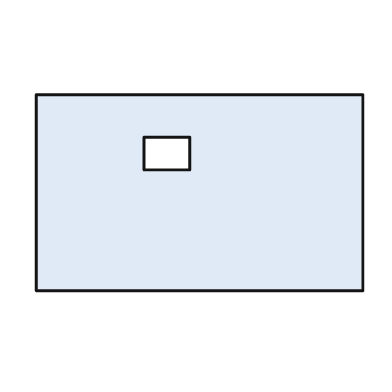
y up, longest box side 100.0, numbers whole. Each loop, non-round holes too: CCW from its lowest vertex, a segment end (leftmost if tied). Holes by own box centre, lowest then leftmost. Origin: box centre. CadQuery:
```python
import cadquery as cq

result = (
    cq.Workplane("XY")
    .moveTo(-50.0, -30.0)
    .lineTo(50.0, -30.0)
    .lineTo(50.0, 30.0)
    .lineTo(-50.0, 30.0)
    .close()
    .moveTo(-17.0, 7.0)
    .lineTo(-3.0, 7.0)
    .lineTo(-3.0, 17.0)
    .lineTo(-17.0, 17.0)
    .close()
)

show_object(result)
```